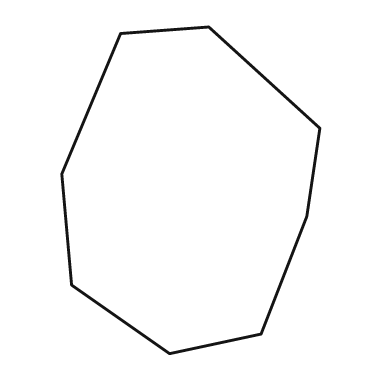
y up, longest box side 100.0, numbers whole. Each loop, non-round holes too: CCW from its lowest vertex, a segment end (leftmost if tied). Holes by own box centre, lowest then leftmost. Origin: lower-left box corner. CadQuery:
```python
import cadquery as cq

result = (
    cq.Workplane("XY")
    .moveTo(33.0, 0.0)
    .lineTo(61.0, 6.0)
    .lineTo(75.0, 42.0)
    .lineTo(79.0, 69.0)
    .lineTo(45.0, 100.0)
    .lineTo(18.0, 98.0)
    .lineTo(0.0, 55.0)
    .lineTo(3.0, 21.0)
    .close()
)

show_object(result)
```